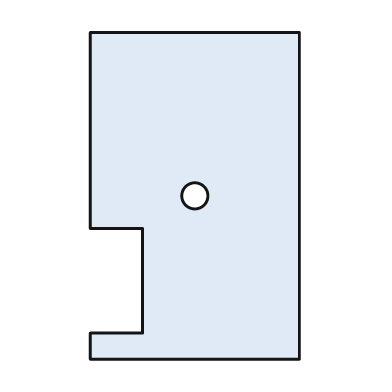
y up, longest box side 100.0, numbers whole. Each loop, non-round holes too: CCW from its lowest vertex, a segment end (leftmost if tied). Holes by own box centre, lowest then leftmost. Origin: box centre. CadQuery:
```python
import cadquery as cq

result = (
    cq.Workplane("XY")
    .moveTo(-32.0, -50.0)
    .lineTo(32.0, -50.0)
    .lineTo(32.0, 50.0)
    .lineTo(-32.0, 50.0)
    .lineTo(-32.0, -10.0)
    .lineTo(-16.0, -10.0)
    .lineTo(-16.0, -42.0)
    .lineTo(-32.0, -42.0)
    .close()
    .moveTo(0.0, 0.0)
    .circle(4.0)
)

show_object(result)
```